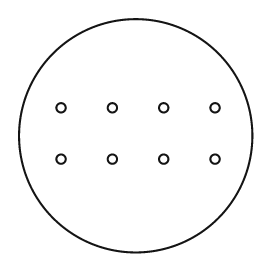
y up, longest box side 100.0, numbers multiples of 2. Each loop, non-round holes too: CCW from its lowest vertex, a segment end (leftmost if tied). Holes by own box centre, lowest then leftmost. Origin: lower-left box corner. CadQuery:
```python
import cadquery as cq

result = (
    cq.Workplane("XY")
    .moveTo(50.0, 50.0)
    .circle(50.0)
    .moveTo(18.0, 40.0)
    .circle(2.0)
    .moveTo(40.0, 40.0)
    .circle(2.0)
    .moveTo(62.0, 40.0)
    .circle(2.0)
    .moveTo(84.0, 40.0)
    .circle(2.0)
    .moveTo(18.0, 62.0)
    .circle(2.0)
    .moveTo(40.0, 62.0)
    .circle(2.0)
    .moveTo(62.0, 62.0)
    .circle(2.0)
    .moveTo(84.0, 62.0)
    .circle(2.0)
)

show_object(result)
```